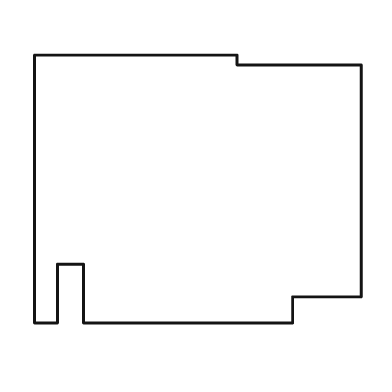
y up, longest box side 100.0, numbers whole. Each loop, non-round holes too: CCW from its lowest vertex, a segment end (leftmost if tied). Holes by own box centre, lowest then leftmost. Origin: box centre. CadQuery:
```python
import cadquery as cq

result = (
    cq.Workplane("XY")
    .moveTo(-50.0, -41.0)
    .lineTo(-43.0, -41.0)
    .lineTo(-43.0, -23.0)
    .lineTo(-35.0, -23.0)
    .lineTo(-35.0, -41.0)
    .lineTo(29.0, -41.0)
    .lineTo(29.0, -33.0)
    .lineTo(50.0, -33.0)
    .lineTo(50.0, 38.0)
    .lineTo(12.0, 38.0)
    .lineTo(12.0, 41.0)
    .lineTo(-50.0, 41.0)
    .close()
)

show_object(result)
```